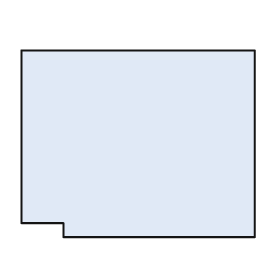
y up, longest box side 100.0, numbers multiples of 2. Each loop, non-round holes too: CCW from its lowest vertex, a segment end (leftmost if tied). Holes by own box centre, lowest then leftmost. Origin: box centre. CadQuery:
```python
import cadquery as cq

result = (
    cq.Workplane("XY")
    .moveTo(-32.0, -40.0)
    .lineTo(50.0, -40.0)
    .lineTo(50.0, 40.0)
    .lineTo(-50.0, 40.0)
    .lineTo(-50.0, -34.0)
    .lineTo(-32.0, -34.0)
    .close()
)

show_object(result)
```